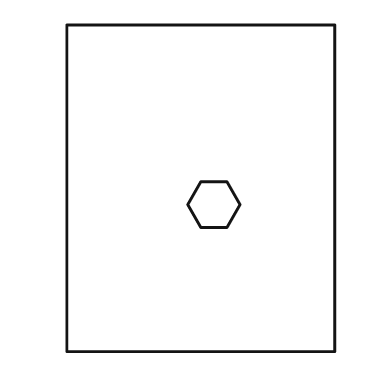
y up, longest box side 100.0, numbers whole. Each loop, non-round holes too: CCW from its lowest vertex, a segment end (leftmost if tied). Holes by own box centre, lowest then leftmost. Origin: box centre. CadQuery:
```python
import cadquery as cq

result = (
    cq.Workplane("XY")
    .moveTo(-41.0, -50.0)
    .lineTo(41.0, -50.0)
    .lineTo(41.0, 50.0)
    .lineTo(-41.0, 50.0)
    .close()
    .moveTo(0.0, -12.0)
    .lineTo(8.0, -12.0)
    .lineTo(12.0, -5.0)
    .lineTo(8.0, 2.0)
    .lineTo(0.0, 2.0)
    .lineTo(-4.0, -5.0)
    .close()
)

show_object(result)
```